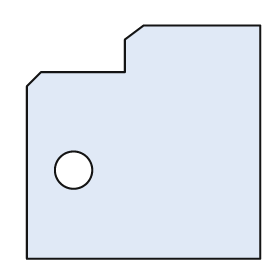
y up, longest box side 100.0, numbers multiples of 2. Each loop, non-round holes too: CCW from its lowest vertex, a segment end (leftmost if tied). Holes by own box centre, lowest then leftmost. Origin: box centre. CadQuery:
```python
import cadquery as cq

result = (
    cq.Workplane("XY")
    .moveTo(-50.0, -50.0)
    .lineTo(50.0, -50.0)
    .lineTo(50.0, 50.0)
    .lineTo(0.0, 50.0)
    .lineTo(-8.0, 44.0)
    .lineTo(-8.0, 30.0)
    .lineTo(-44.0, 30.0)
    .lineTo(-50.0, 24.0)
    .close()
    .moveTo(-30.0, -12.0)
    .circle(8.0)
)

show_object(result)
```